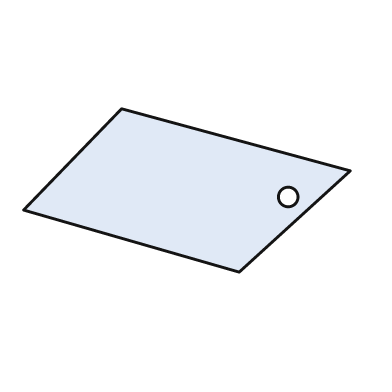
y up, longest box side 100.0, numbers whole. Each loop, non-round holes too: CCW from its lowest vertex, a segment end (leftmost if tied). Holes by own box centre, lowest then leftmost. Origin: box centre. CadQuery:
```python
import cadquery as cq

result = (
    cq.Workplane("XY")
    .moveTo(16.0, -25.0)
    .lineTo(50.0, 6.0)
    .lineTo(-20.0, 25.0)
    .lineTo(-50.0, -6.0)
    .close()
    .moveTo(31.0, -2.0)
    .circle(3.0)
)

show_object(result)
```